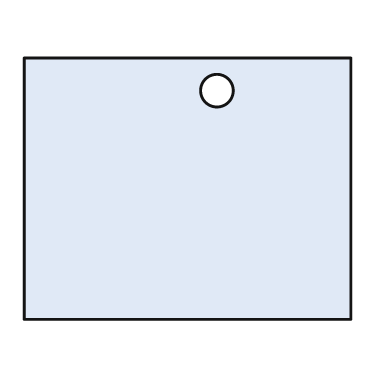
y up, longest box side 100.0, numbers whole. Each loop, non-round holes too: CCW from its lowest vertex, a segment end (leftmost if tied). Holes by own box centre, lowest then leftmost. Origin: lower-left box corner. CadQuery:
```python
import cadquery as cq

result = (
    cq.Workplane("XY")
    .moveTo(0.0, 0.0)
    .lineTo(100.0, 0.0)
    .lineTo(100.0, 80.0)
    .lineTo(0.0, 80.0)
    .close()
    .moveTo(59.0, 70.0)
    .circle(5.0)
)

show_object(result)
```